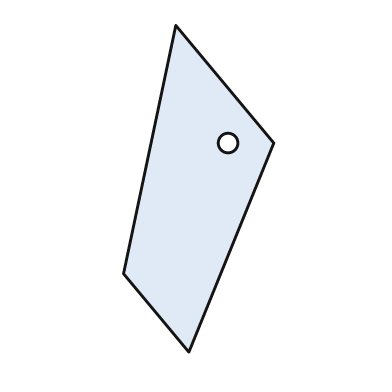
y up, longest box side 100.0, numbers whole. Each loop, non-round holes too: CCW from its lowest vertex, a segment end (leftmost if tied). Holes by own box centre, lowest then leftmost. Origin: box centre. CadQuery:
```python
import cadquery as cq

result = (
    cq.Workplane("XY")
    .moveTo(-3.0, -50.0)
    .lineTo(23.0, 14.0)
    .lineTo(-7.0, 50.0)
    .lineTo(-23.0, -26.0)
    .close()
    .moveTo(9.0, 14.0)
    .circle(3.0)
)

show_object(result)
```